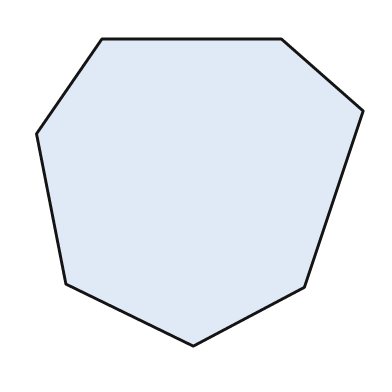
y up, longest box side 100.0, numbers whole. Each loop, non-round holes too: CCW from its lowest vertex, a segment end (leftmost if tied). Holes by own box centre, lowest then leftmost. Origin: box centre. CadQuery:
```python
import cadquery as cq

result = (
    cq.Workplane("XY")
    .moveTo(-2.0, -47.0)
    .lineTo(32.0, -29.0)
    .lineTo(50.0, 25.0)
    .lineTo(25.0, 47.0)
    .lineTo(-30.0, 47.0)
    .lineTo(-50.0, 18.0)
    .lineTo(-41.0, -28.0)
    .close()
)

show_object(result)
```